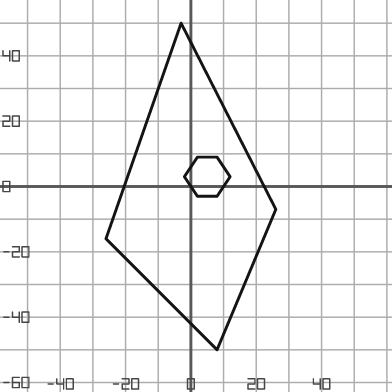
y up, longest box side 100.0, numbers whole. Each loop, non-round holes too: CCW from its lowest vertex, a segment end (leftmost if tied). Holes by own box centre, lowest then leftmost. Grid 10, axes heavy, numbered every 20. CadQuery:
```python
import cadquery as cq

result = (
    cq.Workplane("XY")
    .moveTo(8.0, -50.0)
    .lineTo(26.0, -7.0)
    .lineTo(-3.0, 50.0)
    .lineTo(-26.0, -16.0)
    .close()
    .moveTo(2.0, -3.0)
    .lineTo(8.0, -3.0)
    .lineTo(12.0, 3.0)
    .lineTo(8.0, 9.0)
    .lineTo(2.0, 9.0)
    .lineTo(-2.0, 3.0)
    .close()
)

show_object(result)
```